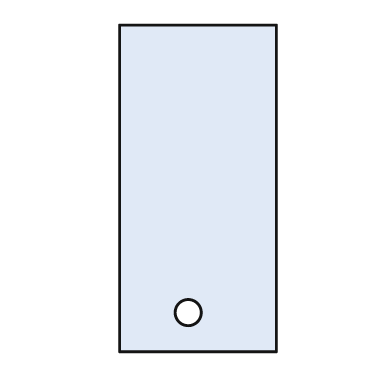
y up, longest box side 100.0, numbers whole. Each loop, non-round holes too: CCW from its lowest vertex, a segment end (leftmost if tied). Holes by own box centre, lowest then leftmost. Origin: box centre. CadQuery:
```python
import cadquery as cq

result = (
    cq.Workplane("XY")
    .moveTo(-24.0, -50.0)
    .lineTo(24.0, -50.0)
    .lineTo(24.0, 50.0)
    .lineTo(-24.0, 50.0)
    .close()
    .moveTo(-3.0, -38.0)
    .circle(4.0)
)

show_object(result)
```